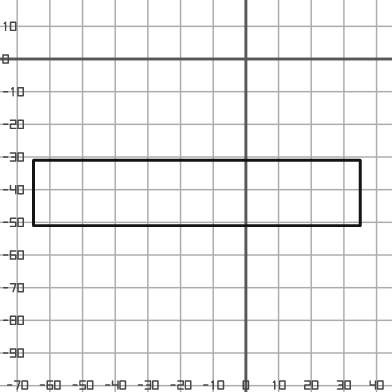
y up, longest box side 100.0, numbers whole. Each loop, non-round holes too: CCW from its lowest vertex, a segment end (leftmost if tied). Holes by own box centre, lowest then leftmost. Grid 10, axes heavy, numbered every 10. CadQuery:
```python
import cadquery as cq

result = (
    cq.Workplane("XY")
    .moveTo(-65.0, -51.0)
    .lineTo(35.0, -51.0)
    .lineTo(35.0, -31.0)
    .lineTo(-65.0, -31.0)
    .close()
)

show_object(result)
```